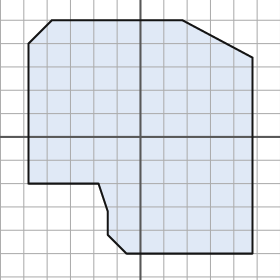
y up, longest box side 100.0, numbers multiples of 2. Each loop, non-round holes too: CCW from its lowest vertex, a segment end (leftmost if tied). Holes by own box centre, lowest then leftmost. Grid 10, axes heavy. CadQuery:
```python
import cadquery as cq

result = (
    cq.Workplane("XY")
    .moveTo(-6.0, -50.0)
    .lineTo(48.0, -50.0)
    .lineTo(48.0, 34.0)
    .lineTo(18.0, 50.0)
    .lineTo(-38.0, 50.0)
    .lineTo(-48.0, 40.0)
    .lineTo(-48.0, -20.0)
    .lineTo(-18.0, -20.0)
    .lineTo(-14.0, -32.0)
    .lineTo(-14.0, -42.0)
    .close()
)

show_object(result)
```